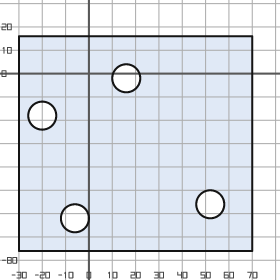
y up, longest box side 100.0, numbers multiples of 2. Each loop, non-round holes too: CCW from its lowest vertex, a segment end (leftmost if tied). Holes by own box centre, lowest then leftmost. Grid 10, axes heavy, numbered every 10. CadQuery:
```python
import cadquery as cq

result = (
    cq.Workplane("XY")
    .moveTo(-30.0, -76.0)
    .lineTo(70.0, -76.0)
    .lineTo(70.0, 16.0)
    .lineTo(-30.0, 16.0)
    .close()
    .moveTo(-6.0, -62.0)
    .circle(6.0)
    .moveTo(52.0, -56.0)
    .circle(6.0)
    .moveTo(-20.0, -18.0)
    .circle(6.0)
    .moveTo(16.0, -2.0)
    .circle(6.0)
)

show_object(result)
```